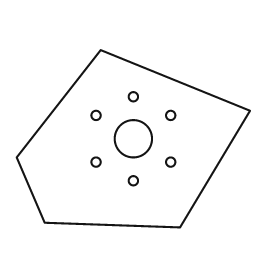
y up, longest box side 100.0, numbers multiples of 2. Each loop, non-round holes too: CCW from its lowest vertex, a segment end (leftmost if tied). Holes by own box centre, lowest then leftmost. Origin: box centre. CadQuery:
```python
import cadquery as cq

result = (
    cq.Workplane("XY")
    .moveTo(20.0, -38.0)
    .lineTo(50.0, 12.0)
    .lineTo(-14.0, 38.0)
    .lineTo(-50.0, -8.0)
    .lineTo(-38.0, -36.0)
    .close()
    .moveTo(0.0, -18.0)
    .circle(2.0)
    .moveTo(-16.0, -10.0)
    .circle(2.0)
    .moveTo(16.0, -10.0)
    .circle(2.0)
    .moveTo(0.0, 0.0)
    .circle(8.0)
    .moveTo(-16.0, 10.0)
    .circle(2.0)
    .moveTo(16.0, 10.0)
    .circle(2.0)
    .moveTo(0.0, 18.0)
    .circle(2.0)
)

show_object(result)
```